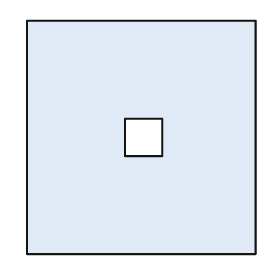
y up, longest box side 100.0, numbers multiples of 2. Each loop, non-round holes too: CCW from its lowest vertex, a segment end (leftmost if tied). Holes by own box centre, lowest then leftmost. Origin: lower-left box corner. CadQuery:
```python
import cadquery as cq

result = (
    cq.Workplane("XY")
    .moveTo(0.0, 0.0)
    .lineTo(98.0, 0.0)
    .lineTo(98.0, 100.0)
    .lineTo(0.0, 100.0)
    .close()
    .moveTo(42.0, 42.0)
    .lineTo(58.0, 42.0)
    .lineTo(58.0, 58.0)
    .lineTo(42.0, 58.0)
    .close()
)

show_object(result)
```